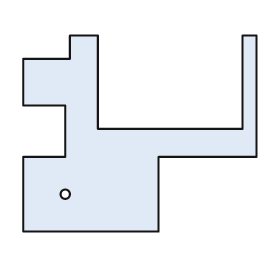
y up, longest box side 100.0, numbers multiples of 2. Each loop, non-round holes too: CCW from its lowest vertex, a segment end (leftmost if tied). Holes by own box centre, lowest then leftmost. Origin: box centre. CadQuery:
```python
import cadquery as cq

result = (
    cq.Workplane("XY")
    .moveTo(-50.0, -42.0)
    .lineTo(8.0, -42.0)
    .lineTo(8.0, -10.0)
    .lineTo(50.0, -10.0)
    .lineTo(50.0, 42.0)
    .lineTo(44.0, 42.0)
    .lineTo(44.0, 2.0)
    .lineTo(-18.0, 2.0)
    .lineTo(-18.0, 42.0)
    .lineTo(-30.0, 42.0)
    .lineTo(-30.0, 32.0)
    .lineTo(-50.0, 32.0)
    .lineTo(-50.0, 12.0)
    .lineTo(-32.0, 12.0)
    .lineTo(-32.0, -10.0)
    .lineTo(-50.0, -10.0)
    .close()
    .moveTo(-32.0, -26.0)
    .circle(2.0)
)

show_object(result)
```